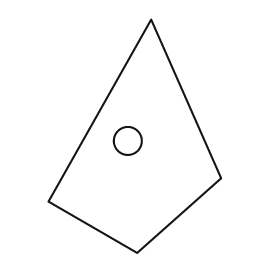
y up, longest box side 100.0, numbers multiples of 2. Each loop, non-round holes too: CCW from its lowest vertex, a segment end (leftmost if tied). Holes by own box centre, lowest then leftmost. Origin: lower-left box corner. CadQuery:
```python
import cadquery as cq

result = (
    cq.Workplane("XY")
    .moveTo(38.0, 0.0)
    .lineTo(74.0, 32.0)
    .lineTo(44.0, 100.0)
    .lineTo(0.0, 22.0)
    .close()
    .moveTo(34.0, 48.0)
    .circle(6.0)
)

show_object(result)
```